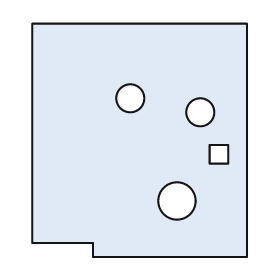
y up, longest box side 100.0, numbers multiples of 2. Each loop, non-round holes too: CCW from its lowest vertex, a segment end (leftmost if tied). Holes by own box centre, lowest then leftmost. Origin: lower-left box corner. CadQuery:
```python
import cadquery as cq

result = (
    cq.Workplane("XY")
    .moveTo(26.0, 0.0)
    .lineTo(92.0, 0.0)
    .lineTo(92.0, 100.0)
    .lineTo(0.0, 100.0)
    .lineTo(0.0, 6.0)
    .lineTo(26.0, 6.0)
    .close()
    .moveTo(62.0, 24.0)
    .circle(8.0)
    .moveTo(76.0, 40.0)
    .lineTo(84.0, 40.0)
    .lineTo(84.0, 48.0)
    .lineTo(76.0, 48.0)
    .close()
    .moveTo(72.0, 62.0)
    .circle(6.0)
    .moveTo(42.0, 68.0)
    .circle(6.0)
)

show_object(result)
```